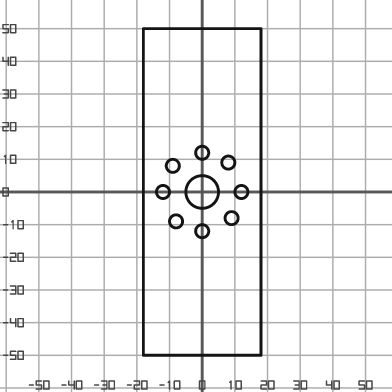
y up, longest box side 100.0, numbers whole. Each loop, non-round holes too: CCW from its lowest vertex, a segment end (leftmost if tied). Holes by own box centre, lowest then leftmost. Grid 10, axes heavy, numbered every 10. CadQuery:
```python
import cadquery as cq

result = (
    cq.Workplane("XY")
    .moveTo(-18.0, -50.0)
    .lineTo(18.0, -50.0)
    .lineTo(18.0, 50.0)
    .lineTo(-18.0, 50.0)
    .close()
    .moveTo(0.0, -12.0)
    .circle(2.0)
    .moveTo(-8.0, -9.0)
    .circle(2.0)
    .moveTo(9.0, -8.0)
    .circle(2.0)
    .moveTo(-12.0, 0.0)
    .circle(2.0)
    .moveTo(0.0, 0.0)
    .circle(5.0)
    .moveTo(12.0, 0.0)
    .circle(2.0)
    .moveTo(-9.0, 8.0)
    .circle(2.0)
    .moveTo(8.0, 9.0)
    .circle(2.0)
    .moveTo(0.0, 12.0)
    .circle(2.0)
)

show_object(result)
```